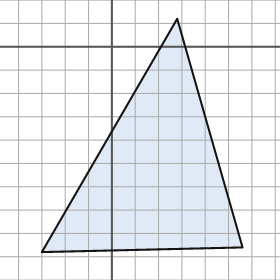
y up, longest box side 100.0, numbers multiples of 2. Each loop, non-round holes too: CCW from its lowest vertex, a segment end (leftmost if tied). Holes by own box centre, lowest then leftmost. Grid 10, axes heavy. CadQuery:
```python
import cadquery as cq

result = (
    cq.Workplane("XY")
    .moveTo(-30.0, -88.0)
    .lineTo(56.0, -86.0)
    .lineTo(28.0, 12.0)
    .close()
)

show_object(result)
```